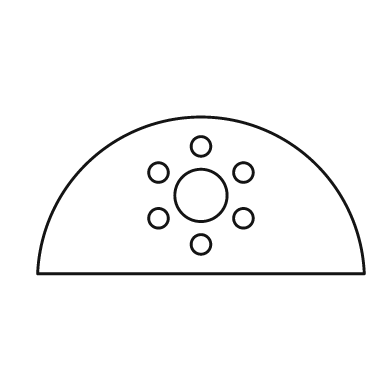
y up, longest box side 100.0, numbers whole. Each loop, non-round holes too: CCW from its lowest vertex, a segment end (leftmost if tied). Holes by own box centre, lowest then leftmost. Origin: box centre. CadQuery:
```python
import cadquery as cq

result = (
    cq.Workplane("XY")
    .moveTo(-50.0, -24.0)
    .lineTo(50.0, -24.0)
    .threePointArc((0.0, 24.0), (-50.0, -24.0))
    .close()
    .moveTo(0.0, -15.0)
    .circle(3.0)
    .moveTo(-13.0, -7.0)
    .circle(3.0)
    .moveTo(13.0, -7.0)
    .circle(3.0)
    .moveTo(0.0, 0.0)
    .circle(8.0)
    .moveTo(-13.0, 7.0)
    .circle(3.0)
    .moveTo(13.0, 7.0)
    .circle(3.0)
    .moveTo(0.0, 15.0)
    .circle(3.0)
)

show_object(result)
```